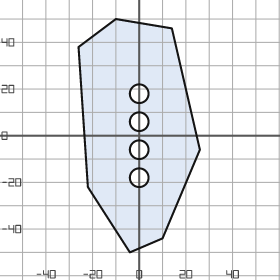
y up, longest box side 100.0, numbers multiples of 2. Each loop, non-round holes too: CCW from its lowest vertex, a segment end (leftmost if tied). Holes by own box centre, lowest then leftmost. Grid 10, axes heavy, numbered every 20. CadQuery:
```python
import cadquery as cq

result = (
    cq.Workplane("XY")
    .moveTo(-4.0, -50.0)
    .lineTo(10.0, -44.0)
    .lineTo(26.0, -6.0)
    .lineTo(14.0, 46.0)
    .lineTo(-10.0, 50.0)
    .lineTo(-26.0, 38.0)
    .lineTo(-22.0, -22.0)
    .close()
    .moveTo(0.0, -18.0)
    .circle(4.0)
    .moveTo(0.0, -6.0)
    .circle(4.0)
    .moveTo(0.0, 6.0)
    .circle(4.0)
    .moveTo(0.0, 18.0)
    .circle(4.0)
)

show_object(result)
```